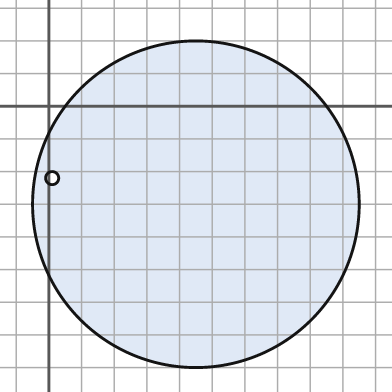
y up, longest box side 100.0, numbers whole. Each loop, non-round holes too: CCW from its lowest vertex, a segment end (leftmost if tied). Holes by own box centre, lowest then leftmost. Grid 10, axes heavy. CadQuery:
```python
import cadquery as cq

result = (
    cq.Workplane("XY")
    .moveTo(45.0, -30.0)
    .circle(50.0)
    .moveTo(1.0, -22.0)
    .circle(2.0)
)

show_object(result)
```